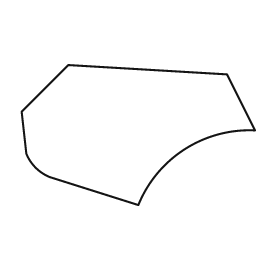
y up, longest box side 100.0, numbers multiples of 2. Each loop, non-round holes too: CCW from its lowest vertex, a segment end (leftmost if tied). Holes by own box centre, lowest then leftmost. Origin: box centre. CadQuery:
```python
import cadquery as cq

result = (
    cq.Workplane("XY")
    .moveTo(0.0, -30.0)
    .threePointArc((20.0, -6.0), (50.0, 2.0))
    .lineTo(38.0, 26.0)
    .lineTo(-30.0, 30.0)
    .lineTo(-50.0, 10.0)
    .lineTo(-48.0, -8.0)
    .threePointArc((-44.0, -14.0), (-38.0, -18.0))
    .close()
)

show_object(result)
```